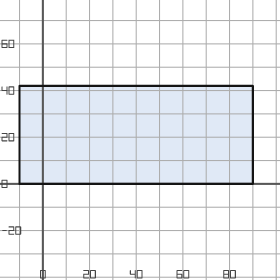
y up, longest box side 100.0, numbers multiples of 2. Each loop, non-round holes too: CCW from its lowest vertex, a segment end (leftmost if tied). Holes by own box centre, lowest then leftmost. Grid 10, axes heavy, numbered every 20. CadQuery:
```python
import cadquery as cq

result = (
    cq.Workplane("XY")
    .moveTo(-10.0, 0.0)
    .lineTo(90.0, 0.0)
    .lineTo(90.0, 42.0)
    .lineTo(-10.0, 42.0)
    .close()
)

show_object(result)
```